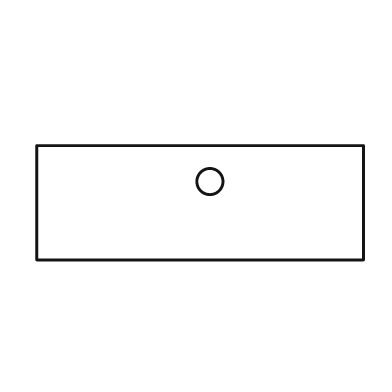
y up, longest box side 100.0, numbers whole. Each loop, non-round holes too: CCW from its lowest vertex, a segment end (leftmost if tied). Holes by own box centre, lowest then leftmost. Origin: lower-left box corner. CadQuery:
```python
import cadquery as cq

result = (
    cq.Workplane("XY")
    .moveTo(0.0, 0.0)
    .lineTo(100.0, 0.0)
    .lineTo(100.0, 35.0)
    .lineTo(0.0, 35.0)
    .close()
    .moveTo(53.0, 24.0)
    .circle(4.0)
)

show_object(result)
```